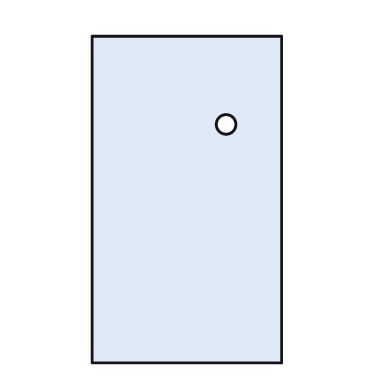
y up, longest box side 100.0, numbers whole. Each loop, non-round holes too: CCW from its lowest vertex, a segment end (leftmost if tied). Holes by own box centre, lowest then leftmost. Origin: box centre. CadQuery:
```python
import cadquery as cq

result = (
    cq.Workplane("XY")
    .moveTo(-29.0, -50.0)
    .lineTo(29.0, -50.0)
    .lineTo(29.0, 50.0)
    .lineTo(-29.0, 50.0)
    .close()
    .moveTo(12.0, 23.0)
    .circle(3.0)
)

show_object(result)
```